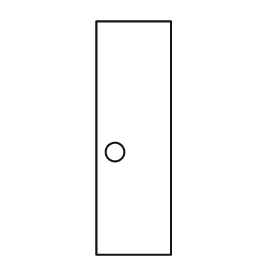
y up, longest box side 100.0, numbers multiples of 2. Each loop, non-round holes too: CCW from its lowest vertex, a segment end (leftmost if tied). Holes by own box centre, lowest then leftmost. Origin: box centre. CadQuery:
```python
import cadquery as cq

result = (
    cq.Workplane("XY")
    .moveTo(-16.0, -50.0)
    .lineTo(16.0, -50.0)
    .lineTo(16.0, 50.0)
    .lineTo(-16.0, 50.0)
    .close()
    .moveTo(-8.0, -6.0)
    .circle(4.0)
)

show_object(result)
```